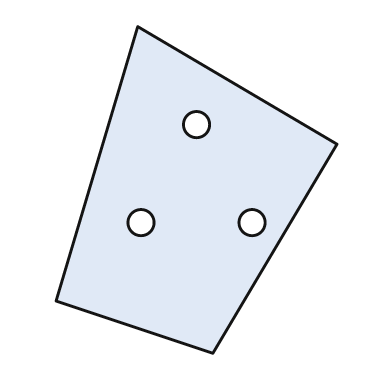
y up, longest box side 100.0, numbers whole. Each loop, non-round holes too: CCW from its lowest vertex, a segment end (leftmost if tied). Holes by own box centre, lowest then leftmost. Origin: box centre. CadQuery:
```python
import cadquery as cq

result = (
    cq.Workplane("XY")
    .moveTo(5.0, -50.0)
    .lineTo(43.0, 14.0)
    .lineTo(-18.0, 50.0)
    .lineTo(-43.0, -34.0)
    .close()
    .moveTo(-17.0, -10.0)
    .circle(4.0)
    .moveTo(17.0, -10.0)
    .circle(4.0)
    .moveTo(0.0, 20.0)
    .circle(4.0)
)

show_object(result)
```